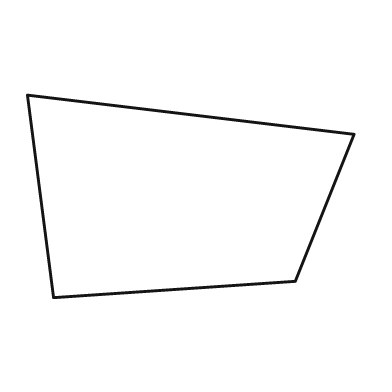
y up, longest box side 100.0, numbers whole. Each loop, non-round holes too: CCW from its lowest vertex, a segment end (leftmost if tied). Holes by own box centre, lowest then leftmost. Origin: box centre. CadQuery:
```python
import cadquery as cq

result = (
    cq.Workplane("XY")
    .moveTo(-42.0, -31.0)
    .lineTo(32.0, -26.0)
    .lineTo(50.0, 19.0)
    .lineTo(-50.0, 31.0)
    .close()
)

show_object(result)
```